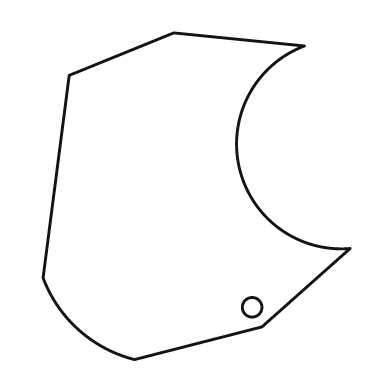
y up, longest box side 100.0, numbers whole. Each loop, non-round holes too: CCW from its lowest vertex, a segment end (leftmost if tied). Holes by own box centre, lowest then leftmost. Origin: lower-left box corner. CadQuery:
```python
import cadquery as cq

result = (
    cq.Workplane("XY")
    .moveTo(28.0, 0.0)
    .lineTo(67.0, 10.0)
    .lineTo(94.0, 34.0)
    .threePointArc((60.0, 59.0), (80.0, 96.0))
    .lineTo(40.0, 100.0)
    .lineTo(8.0, 87.0)
    .lineTo(0.0, 25.0)
    .threePointArc((11.0, 9.0), (28.0, 0.0))
    .close()
    .moveTo(64.0, 16.0)
    .circle(3.0)
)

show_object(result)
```